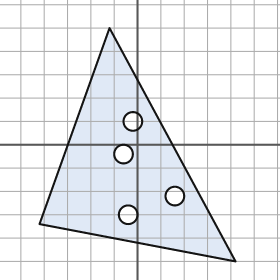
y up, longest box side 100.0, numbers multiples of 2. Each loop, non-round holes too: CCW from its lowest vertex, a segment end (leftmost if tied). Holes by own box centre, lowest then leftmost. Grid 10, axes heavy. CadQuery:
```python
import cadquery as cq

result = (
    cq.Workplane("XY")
    .moveTo(42.0, -50.0)
    .lineTo(-12.0, 50.0)
    .lineTo(-42.0, -34.0)
    .close()
    .moveTo(-4.0, -30.0)
    .circle(4.0)
    .moveTo(16.0, -22.0)
    .circle(4.0)
    .moveTo(-6.0, -4.0)
    .circle(4.0)
    .moveTo(-2.0, 10.0)
    .circle(4.0)
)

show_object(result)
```